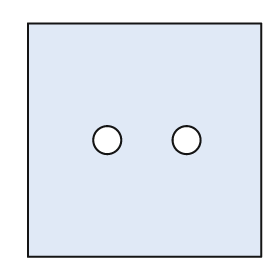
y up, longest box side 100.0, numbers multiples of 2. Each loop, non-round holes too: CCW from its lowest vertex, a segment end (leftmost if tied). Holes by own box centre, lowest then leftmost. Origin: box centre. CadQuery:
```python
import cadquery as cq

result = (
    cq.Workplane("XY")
    .moveTo(-50.0, -50.0)
    .lineTo(50.0, -50.0)
    .lineTo(50.0, 50.0)
    .lineTo(-50.0, 50.0)
    .close()
    .moveTo(-16.0, 0.0)
    .circle(6.0)
    .moveTo(18.0, 0.0)
    .circle(6.0)
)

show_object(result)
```